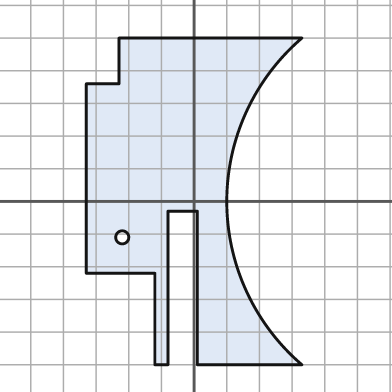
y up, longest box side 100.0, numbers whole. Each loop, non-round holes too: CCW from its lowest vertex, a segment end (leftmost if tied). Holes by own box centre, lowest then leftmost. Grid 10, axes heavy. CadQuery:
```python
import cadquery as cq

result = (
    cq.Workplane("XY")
    .moveTo(-12.0, -50.0)
    .lineTo(-8.0, -50.0)
    .lineTo(-8.0, -3.0)
    .lineTo(1.0, -3.0)
    .lineTo(1.0, -50.0)
    .lineTo(33.0, -50.0)
    .threePointArc((10.0, 0.0), (33.0, 50.0))
    .lineTo(-23.0, 50.0)
    .lineTo(-23.0, 36.0)
    .lineTo(-33.0, 36.0)
    .lineTo(-33.0, -22.0)
    .lineTo(-12.0, -22.0)
    .close()
    .moveTo(-22.0, -11.0)
    .circle(2.0)
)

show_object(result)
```